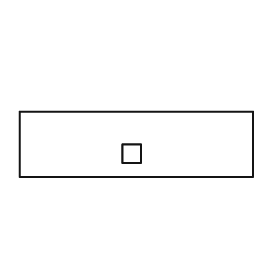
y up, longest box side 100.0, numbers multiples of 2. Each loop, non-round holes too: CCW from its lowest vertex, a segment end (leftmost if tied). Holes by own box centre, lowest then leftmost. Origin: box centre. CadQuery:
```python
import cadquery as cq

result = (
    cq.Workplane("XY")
    .moveTo(-50.0, -14.0)
    .lineTo(50.0, -14.0)
    .lineTo(50.0, 14.0)
    .lineTo(-50.0, 14.0)
    .close()
    .moveTo(-6.0, -8.0)
    .lineTo(2.0, -8.0)
    .lineTo(2.0, 0.0)
    .lineTo(-6.0, 0.0)
    .close()
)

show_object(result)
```